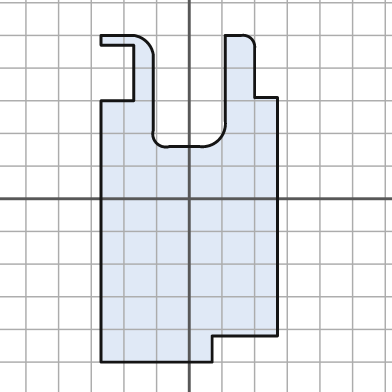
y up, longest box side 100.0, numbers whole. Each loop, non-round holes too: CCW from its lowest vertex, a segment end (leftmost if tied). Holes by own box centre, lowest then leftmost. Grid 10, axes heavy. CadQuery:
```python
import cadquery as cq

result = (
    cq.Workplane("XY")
    .moveTo(-27.0, -50.0)
    .lineTo(7.0, -50.0)
    .lineTo(7.0, -42.0)
    .lineTo(27.0, -42.0)
    .lineTo(27.0, 31.0)
    .lineTo(20.0, 31.0)
    .lineTo(20.0, 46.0)
    .threePointArc((19.0, 49.0), (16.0, 50.0))
    .lineTo(11.0, 50.0)
    .lineTo(11.0, 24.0)
    .threePointArc((9.0, 18.0), (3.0, 16.0))
    .lineTo(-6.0, 16.0)
    .threePointArc((-10.0, 17.0), (-11.0, 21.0))
    .lineTo(-11.0, 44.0)
    .threePointArc((-13.0, 48.0), (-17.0, 50.0))
    .lineTo(-27.0, 50.0)
    .lineTo(-27.0, 47.0)
    .lineTo(-17.0, 47.0)
    .lineTo(-17.0, 30.0)
    .lineTo(-27.0, 30.0)
    .close()
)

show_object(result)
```